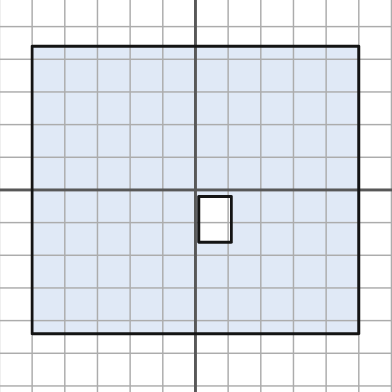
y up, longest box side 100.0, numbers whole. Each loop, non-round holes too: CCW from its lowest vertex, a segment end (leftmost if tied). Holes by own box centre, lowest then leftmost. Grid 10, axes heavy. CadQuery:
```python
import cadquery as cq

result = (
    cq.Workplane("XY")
    .moveTo(-50.0, -44.0)
    .lineTo(50.0, -44.0)
    .lineTo(50.0, 44.0)
    .lineTo(-50.0, 44.0)
    .close()
    .moveTo(1.0, -16.0)
    .lineTo(11.0, -16.0)
    .lineTo(11.0, -2.0)
    .lineTo(1.0, -2.0)
    .close()
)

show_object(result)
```